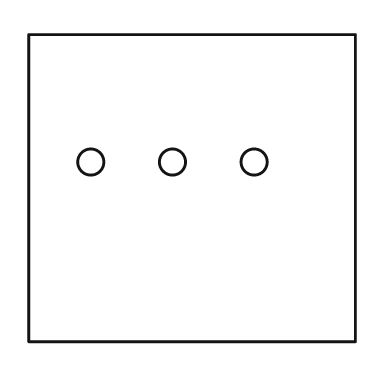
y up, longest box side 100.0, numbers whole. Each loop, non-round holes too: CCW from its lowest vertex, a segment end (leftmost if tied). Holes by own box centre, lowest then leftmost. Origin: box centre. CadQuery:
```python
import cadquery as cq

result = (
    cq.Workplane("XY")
    .moveTo(-50.0, -47.0)
    .lineTo(50.0, -47.0)
    .lineTo(50.0, 47.0)
    .lineTo(-50.0, 47.0)
    .close()
    .moveTo(-31.0, 8.0)
    .circle(4.0)
    .moveTo(-6.0, 8.0)
    .circle(4.0)
    .moveTo(19.0, 8.0)
    .circle(4.0)
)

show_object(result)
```